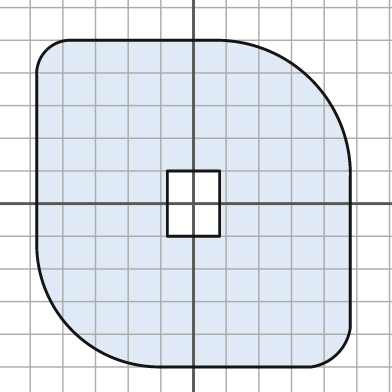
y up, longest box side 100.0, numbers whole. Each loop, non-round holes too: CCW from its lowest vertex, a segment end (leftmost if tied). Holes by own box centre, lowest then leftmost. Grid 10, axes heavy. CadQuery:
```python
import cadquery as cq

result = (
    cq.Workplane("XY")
    .moveTo(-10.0, -50.0)
    .lineTo(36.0, -50.0)
    .threePointArc((44.0, -46.0), (48.0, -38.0))
    .lineTo(48.0, 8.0)
    .threePointArc((36.0, 38.0), (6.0, 50.0))
    .lineTo(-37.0, 50.0)
    .threePointArc((-45.0, 47.0), (-48.0, 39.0))
    .lineTo(-48.0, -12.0)
    .threePointArc((-37.0, -39.0), (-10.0, -50.0))
    .close()
    .moveTo(-8.0, -10.0)
    .lineTo(8.0, -10.0)
    .lineTo(8.0, 10.0)
    .lineTo(-8.0, 10.0)
    .close()
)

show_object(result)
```